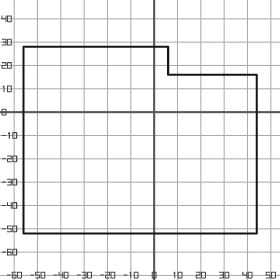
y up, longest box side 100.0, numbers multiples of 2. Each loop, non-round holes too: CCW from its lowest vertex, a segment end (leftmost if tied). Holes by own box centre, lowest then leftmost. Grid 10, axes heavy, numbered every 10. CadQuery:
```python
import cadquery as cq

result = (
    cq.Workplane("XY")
    .moveTo(-56.0, -52.0)
    .lineTo(44.0, -52.0)
    .lineTo(44.0, 16.0)
    .lineTo(6.0, 16.0)
    .lineTo(6.0, 28.0)
    .lineTo(-56.0, 28.0)
    .close()
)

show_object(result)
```